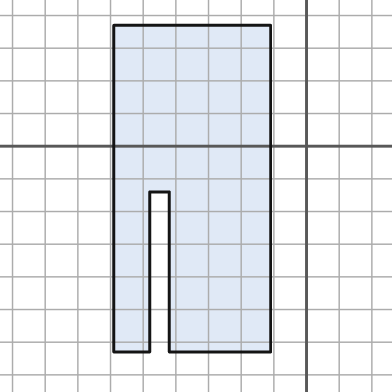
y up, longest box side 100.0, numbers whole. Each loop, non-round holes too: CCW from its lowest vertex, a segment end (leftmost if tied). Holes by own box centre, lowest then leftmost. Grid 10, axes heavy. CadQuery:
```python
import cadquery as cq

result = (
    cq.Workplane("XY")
    .moveTo(-59.0, -63.0)
    .lineTo(-48.0, -63.0)
    .lineTo(-48.0, -14.0)
    .lineTo(-42.0, -14.0)
    .lineTo(-42.0, -63.0)
    .lineTo(-11.0, -63.0)
    .lineTo(-11.0, 37.0)
    .lineTo(-59.0, 37.0)
    .close()
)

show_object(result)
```